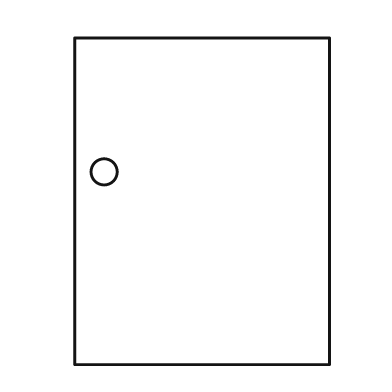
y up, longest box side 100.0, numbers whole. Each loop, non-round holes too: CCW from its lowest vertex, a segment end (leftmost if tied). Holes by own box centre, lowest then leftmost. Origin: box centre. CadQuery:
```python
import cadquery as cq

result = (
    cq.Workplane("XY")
    .moveTo(-39.0, -50.0)
    .lineTo(39.0, -50.0)
    .lineTo(39.0, 50.0)
    .lineTo(-39.0, 50.0)
    .close()
    .moveTo(-30.0, 9.0)
    .circle(4.0)
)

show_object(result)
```